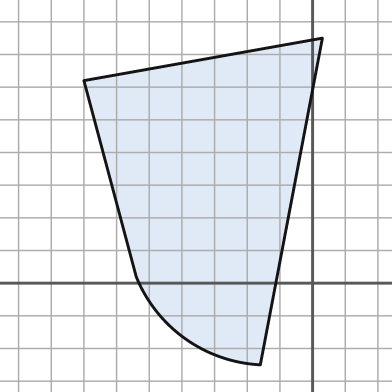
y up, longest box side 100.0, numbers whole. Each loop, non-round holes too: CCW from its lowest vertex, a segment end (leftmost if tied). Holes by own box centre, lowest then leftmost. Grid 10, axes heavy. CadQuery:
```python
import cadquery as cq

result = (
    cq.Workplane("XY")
    .moveTo(-16.0, -25.0)
    .lineTo(3.0, 75.0)
    .lineTo(-70.0, 62.0)
    .lineTo(-54.0, 2.0)
    .threePointArc((-39.0, -17.0), (-16.0, -25.0))
    .close()
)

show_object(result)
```